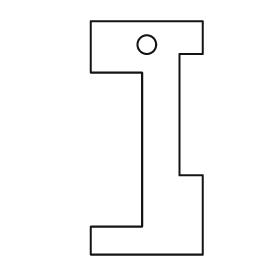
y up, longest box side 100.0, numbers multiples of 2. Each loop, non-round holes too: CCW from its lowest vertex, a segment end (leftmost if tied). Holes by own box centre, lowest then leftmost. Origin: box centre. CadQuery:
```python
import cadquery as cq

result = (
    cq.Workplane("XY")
    .moveTo(-24.0, -50.0)
    .lineTo(24.0, -50.0)
    .lineTo(24.0, -16.0)
    .lineTo(14.0, -16.0)
    .lineTo(14.0, 36.0)
    .lineTo(24.0, 36.0)
    .lineTo(24.0, 50.0)
    .lineTo(-24.0, 50.0)
    .lineTo(-24.0, 28.0)
    .lineTo(-2.0, 28.0)
    .lineTo(-2.0, -38.0)
    .lineTo(-24.0, -38.0)
    .close()
    .moveTo(0.0, 40.0)
    .circle(4.0)
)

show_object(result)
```